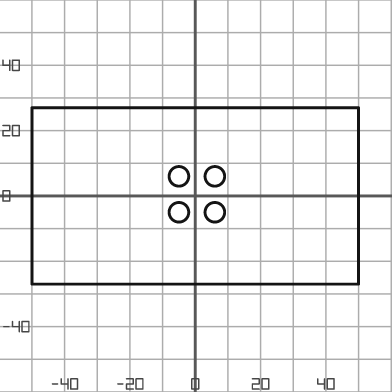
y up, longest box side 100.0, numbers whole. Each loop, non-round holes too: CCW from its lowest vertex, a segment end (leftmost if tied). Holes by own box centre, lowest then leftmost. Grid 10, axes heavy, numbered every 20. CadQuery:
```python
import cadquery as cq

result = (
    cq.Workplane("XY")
    .moveTo(-50.0, -27.0)
    .lineTo(50.0, -27.0)
    .lineTo(50.0, 27.0)
    .lineTo(-50.0, 27.0)
    .close()
    .moveTo(-5.0, -5.0)
    .circle(3.0)
    .moveTo(6.0, -5.0)
    .circle(3.0)
    .moveTo(-5.0, 6.0)
    .circle(3.0)
    .moveTo(6.0, 6.0)
    .circle(3.0)
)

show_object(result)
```